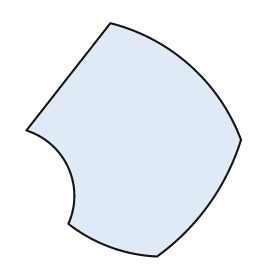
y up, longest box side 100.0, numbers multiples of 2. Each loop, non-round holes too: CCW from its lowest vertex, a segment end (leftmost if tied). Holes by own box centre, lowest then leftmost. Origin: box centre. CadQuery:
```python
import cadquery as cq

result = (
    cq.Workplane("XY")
    .moveTo(10.0, -50.0)
    .threePointArc((32.0, -28.0), (46.0, 0.0))
    .threePointArc((24.0, 32.0), (-10.0, 50.0))
    .lineTo(-46.0, 4.0)
    .threePointArc((-28.0, -12.0), (-28.0, -36.0))
    .threePointArc((-10.0, -46.0), (10.0, -50.0))
    .close()
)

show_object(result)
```